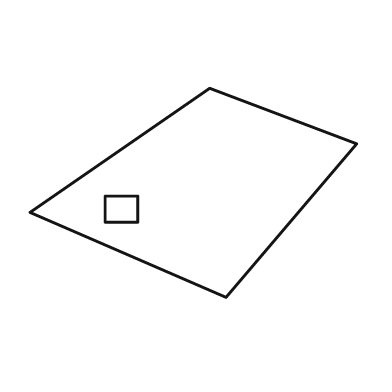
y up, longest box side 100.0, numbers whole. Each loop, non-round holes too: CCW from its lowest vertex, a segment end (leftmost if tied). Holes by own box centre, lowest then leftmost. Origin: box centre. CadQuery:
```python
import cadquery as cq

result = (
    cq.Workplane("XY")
    .moveTo(10.0, -32.0)
    .lineTo(50.0, 15.0)
    .lineTo(5.0, 32.0)
    .lineTo(-50.0, -6.0)
    .close()
    .moveTo(-27.0, -9.0)
    .lineTo(-17.0, -9.0)
    .lineTo(-17.0, -1.0)
    .lineTo(-27.0, -1.0)
    .close()
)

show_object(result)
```